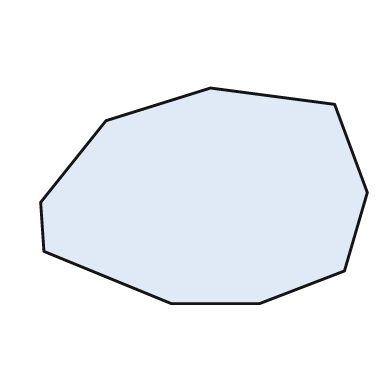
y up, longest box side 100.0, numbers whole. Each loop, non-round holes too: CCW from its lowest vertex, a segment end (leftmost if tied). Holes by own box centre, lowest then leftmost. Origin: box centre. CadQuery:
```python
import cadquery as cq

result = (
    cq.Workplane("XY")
    .moveTo(-10.0, -33.0)
    .lineTo(17.0, -33.0)
    .lineTo(43.0, -23.0)
    .lineTo(50.0, 1.0)
    .lineTo(40.0, 28.0)
    .lineTo(2.0, 33.0)
    .lineTo(-30.0, 23.0)
    .lineTo(-50.0, -2.0)
    .lineTo(-49.0, -17.0)
    .close()
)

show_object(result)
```